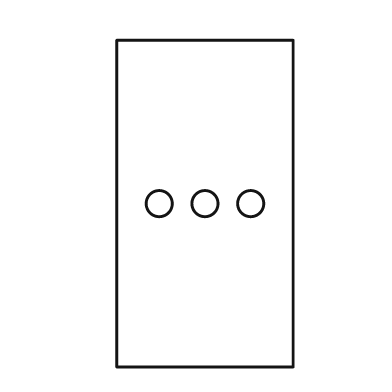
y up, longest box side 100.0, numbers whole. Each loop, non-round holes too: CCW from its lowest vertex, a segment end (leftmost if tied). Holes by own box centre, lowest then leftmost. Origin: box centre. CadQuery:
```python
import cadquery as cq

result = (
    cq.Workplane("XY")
    .moveTo(-27.0, -50.0)
    .lineTo(27.0, -50.0)
    .lineTo(27.0, 50.0)
    .lineTo(-27.0, 50.0)
    .close()
    .moveTo(-14.0, 0.0)
    .circle(4.0)
    .moveTo(0.0, 0.0)
    .circle(4.0)
    .moveTo(14.0, 0.0)
    .circle(4.0)
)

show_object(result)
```